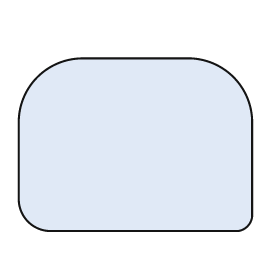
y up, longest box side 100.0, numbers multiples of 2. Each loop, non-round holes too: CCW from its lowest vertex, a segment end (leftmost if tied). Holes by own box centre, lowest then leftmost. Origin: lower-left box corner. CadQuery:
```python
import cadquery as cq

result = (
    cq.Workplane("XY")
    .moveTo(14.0, 0.0)
    .lineTo(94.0, 0.0)
    .threePointArc((98.0, 2.0), (100.0, 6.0))
    .lineTo(100.0, 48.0)
    .threePointArc((92.0, 66.0), (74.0, 74.0))
    .lineTo(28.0, 74.0)
    .threePointArc((8.0, 66.0), (0.0, 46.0))
    .lineTo(0.0, 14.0)
    .threePointArc((4.0, 4.0), (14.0, 0.0))
    .close()
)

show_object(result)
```